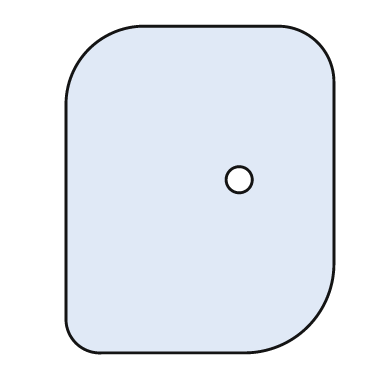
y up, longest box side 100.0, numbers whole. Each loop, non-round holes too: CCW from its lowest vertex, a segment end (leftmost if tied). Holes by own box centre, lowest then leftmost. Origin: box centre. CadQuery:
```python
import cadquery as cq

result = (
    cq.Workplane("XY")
    .moveTo(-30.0, -50.0)
    .lineTo(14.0, -50.0)
    .threePointArc((33.0, -42.0), (41.0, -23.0))
    .lineTo(41.0, 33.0)
    .threePointArc((36.0, 45.0), (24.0, 50.0))
    .lineTo(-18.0, 50.0)
    .threePointArc((-34.0, 43.0), (-41.0, 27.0))
    .lineTo(-41.0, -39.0)
    .threePointArc((-38.0, -47.0), (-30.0, -50.0))
    .close()
    .moveTo(12.0, 3.0)
    .circle(4.0)
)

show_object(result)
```